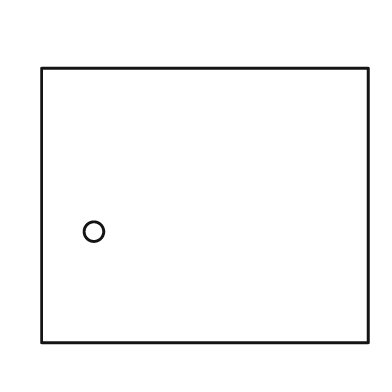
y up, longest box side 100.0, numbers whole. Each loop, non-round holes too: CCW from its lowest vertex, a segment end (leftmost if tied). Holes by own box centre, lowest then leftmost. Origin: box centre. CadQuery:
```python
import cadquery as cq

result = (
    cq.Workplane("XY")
    .moveTo(-50.0, -42.0)
    .lineTo(50.0, -42.0)
    .lineTo(50.0, 42.0)
    .lineTo(-50.0, 42.0)
    .close()
    .moveTo(-34.0, -8.0)
    .circle(3.0)
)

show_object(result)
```